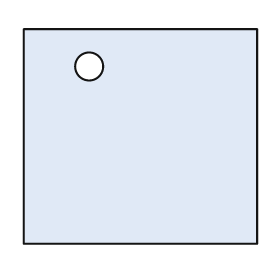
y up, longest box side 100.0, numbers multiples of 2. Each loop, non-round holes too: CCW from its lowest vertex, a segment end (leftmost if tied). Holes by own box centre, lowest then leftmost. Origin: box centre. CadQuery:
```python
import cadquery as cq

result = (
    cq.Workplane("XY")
    .moveTo(-50.0, -46.0)
    .lineTo(50.0, -46.0)
    .lineTo(50.0, 46.0)
    .lineTo(-50.0, 46.0)
    .close()
    .moveTo(-22.0, 30.0)
    .circle(6.0)
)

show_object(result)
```